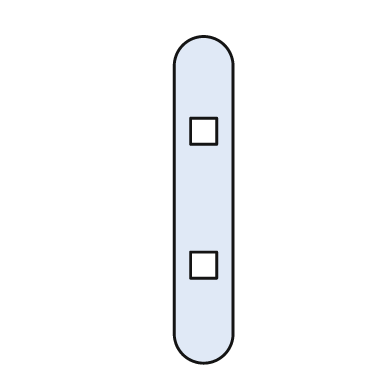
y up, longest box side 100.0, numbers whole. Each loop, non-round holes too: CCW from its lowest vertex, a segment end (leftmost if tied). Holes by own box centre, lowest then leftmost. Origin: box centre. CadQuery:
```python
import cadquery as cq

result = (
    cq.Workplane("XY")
    .moveTo(-9.0, -41.0)
    .threePointArc((0.0, -50.0), (9.0, -41.0))
    .lineTo(9.0, 41.0)
    .threePointArc((0.0, 50.0), (-9.0, 41.0))
    .close()
    .moveTo(-4.0, -24.0)
    .lineTo(4.0, -24.0)
    .lineTo(4.0, -16.0)
    .lineTo(-4.0, -16.0)
    .close()
    .moveTo(-4.0, 17.0)
    .lineTo(4.0, 17.0)
    .lineTo(4.0, 25.0)
    .lineTo(-4.0, 25.0)
    .close()
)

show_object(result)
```